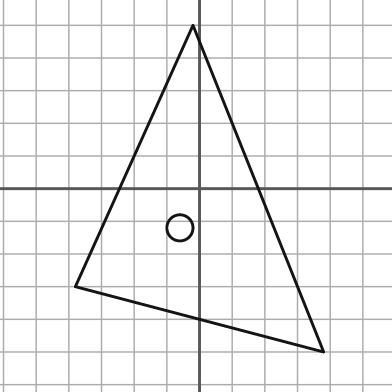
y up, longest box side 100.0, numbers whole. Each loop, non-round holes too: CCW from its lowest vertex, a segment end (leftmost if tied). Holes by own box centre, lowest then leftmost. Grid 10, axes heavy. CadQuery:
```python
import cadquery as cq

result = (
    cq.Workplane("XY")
    .moveTo(38.0, -50.0)
    .lineTo(-2.0, 50.0)
    .lineTo(-38.0, -30.0)
    .close()
    .moveTo(-6.0, -12.0)
    .circle(4.0)
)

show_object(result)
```